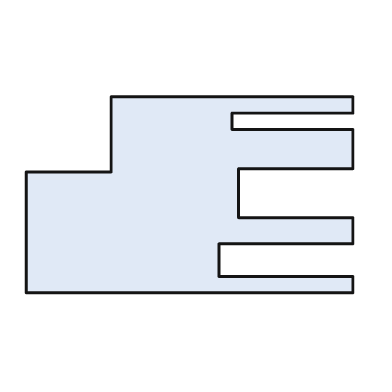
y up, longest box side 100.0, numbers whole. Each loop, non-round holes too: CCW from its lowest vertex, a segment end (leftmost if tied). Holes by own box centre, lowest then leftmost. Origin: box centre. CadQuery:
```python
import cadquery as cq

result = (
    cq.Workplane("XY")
    .moveTo(-50.0, -30.0)
    .lineTo(50.0, -30.0)
    .lineTo(50.0, -25.0)
    .lineTo(9.0, -25.0)
    .lineTo(9.0, -15.0)
    .lineTo(50.0, -15.0)
    .lineTo(50.0, -7.0)
    .lineTo(15.0, -7.0)
    .lineTo(15.0, 8.0)
    .lineTo(50.0, 8.0)
    .lineTo(50.0, 20.0)
    .lineTo(13.0, 20.0)
    .lineTo(13.0, 25.0)
    .lineTo(50.0, 25.0)
    .lineTo(50.0, 30.0)
    .lineTo(-24.0, 30.0)
    .lineTo(-24.0, 7.0)
    .lineTo(-50.0, 7.0)
    .close()
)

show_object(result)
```